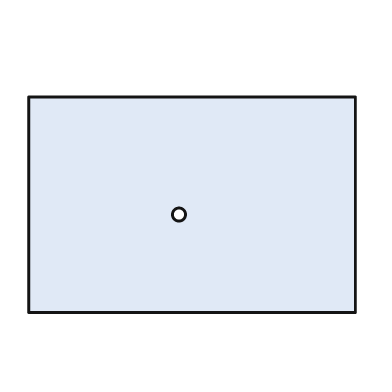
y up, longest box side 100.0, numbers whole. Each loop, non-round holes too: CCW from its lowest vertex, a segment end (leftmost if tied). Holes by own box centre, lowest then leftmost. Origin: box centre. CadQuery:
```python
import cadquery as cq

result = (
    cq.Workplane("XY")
    .moveTo(-50.0, -33.0)
    .lineTo(50.0, -33.0)
    .lineTo(50.0, 33.0)
    .lineTo(-50.0, 33.0)
    .close()
    .moveTo(-4.0, -3.0)
    .circle(2.0)
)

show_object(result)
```